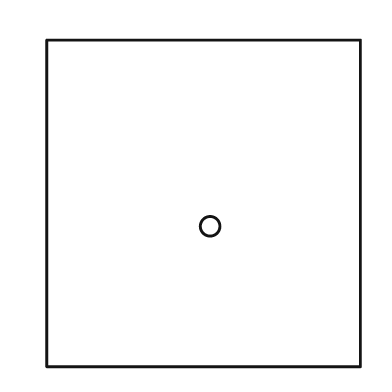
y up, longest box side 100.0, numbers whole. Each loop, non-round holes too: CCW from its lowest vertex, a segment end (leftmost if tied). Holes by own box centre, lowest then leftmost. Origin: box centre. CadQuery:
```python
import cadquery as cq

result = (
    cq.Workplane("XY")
    .moveTo(-48.0, -50.0)
    .lineTo(48.0, -50.0)
    .lineTo(48.0, 50.0)
    .lineTo(-48.0, 50.0)
    .close()
    .moveTo(2.0, -7.0)
    .circle(3.0)
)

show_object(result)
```